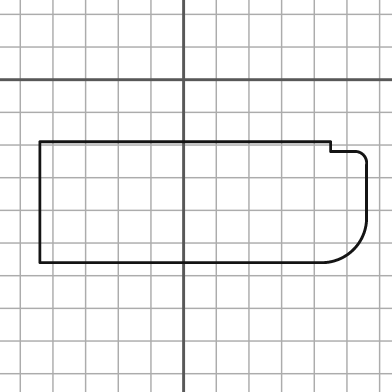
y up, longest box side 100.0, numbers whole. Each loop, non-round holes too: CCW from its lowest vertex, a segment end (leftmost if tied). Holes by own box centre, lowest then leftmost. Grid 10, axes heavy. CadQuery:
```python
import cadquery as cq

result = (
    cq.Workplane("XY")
    .moveTo(-44.0, -56.0)
    .lineTo(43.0, -56.0)
    .threePointArc((52.0, -52.0), (56.0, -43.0))
    .lineTo(56.0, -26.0)
    .threePointArc((55.0, -23.0), (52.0, -22.0))
    .lineTo(45.0, -22.0)
    .lineTo(45.0, -19.0)
    .lineTo(-44.0, -19.0)
    .close()
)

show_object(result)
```